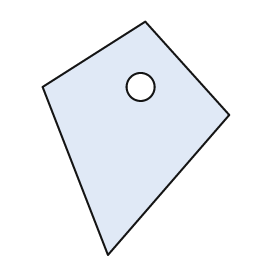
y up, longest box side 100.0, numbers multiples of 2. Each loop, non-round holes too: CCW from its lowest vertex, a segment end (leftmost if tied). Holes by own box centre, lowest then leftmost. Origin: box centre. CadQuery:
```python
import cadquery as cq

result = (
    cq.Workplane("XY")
    .moveTo(-12.0, -50.0)
    .lineTo(40.0, 10.0)
    .lineTo(4.0, 50.0)
    .lineTo(-40.0, 22.0)
    .close()
    .moveTo(2.0, 22.0)
    .circle(6.0)
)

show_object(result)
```